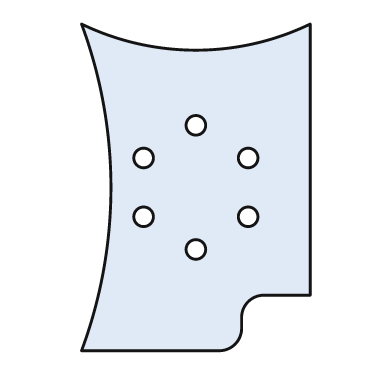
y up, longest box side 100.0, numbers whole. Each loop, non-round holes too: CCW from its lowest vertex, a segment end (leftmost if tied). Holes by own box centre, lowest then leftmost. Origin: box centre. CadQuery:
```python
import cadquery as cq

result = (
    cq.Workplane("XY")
    .moveTo(-35.0, -50.0)
    .lineTo(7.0, -50.0)
    .threePointArc((12.0, -48.0), (14.0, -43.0))
    .lineTo(14.0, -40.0)
    .threePointArc((16.0, -35.0), (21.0, -33.0))
    .lineTo(35.0, -33.0)
    .lineTo(35.0, 50.0)
    .threePointArc((0.0, 42.0), (-35.0, 50.0))
    .threePointArc((-26.0, 0.0), (-35.0, -50.0))
    .close()
    .moveTo(0.0, -19.0)
    .circle(3.0)
    .moveTo(-16.0, -9.0)
    .circle(3.0)
    .moveTo(16.0, -9.0)
    .circle(3.0)
    .moveTo(-16.0, 9.0)
    .circle(3.0)
    .moveTo(16.0, 9.0)
    .circle(3.0)
    .moveTo(0.0, 19.0)
    .circle(3.0)
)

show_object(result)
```